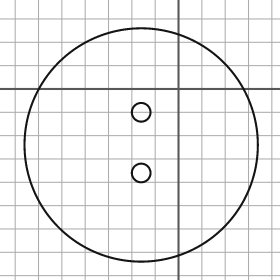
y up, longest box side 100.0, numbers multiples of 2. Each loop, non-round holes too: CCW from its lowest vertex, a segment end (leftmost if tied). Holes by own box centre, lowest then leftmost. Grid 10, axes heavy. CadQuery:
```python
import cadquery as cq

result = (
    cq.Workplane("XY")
    .moveTo(-16.0, -24.0)
    .circle(50.0)
    .moveTo(-16.0, -36.0)
    .circle(4.0)
    .moveTo(-16.0, -10.0)
    .circle(4.0)
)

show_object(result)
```